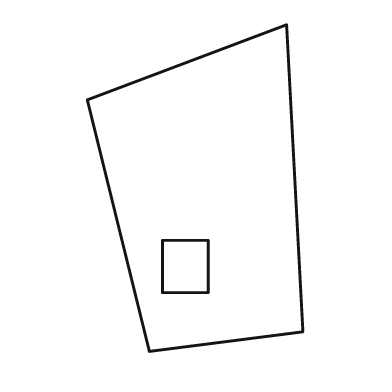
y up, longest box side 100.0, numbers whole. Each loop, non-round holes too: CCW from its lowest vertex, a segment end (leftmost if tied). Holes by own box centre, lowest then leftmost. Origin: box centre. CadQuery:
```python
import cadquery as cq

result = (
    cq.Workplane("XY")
    .moveTo(-14.0, -50.0)
    .lineTo(33.0, -44.0)
    .lineTo(28.0, 50.0)
    .lineTo(-33.0, 27.0)
    .close()
    .moveTo(-10.0, -32.0)
    .lineTo(4.0, -32.0)
    .lineTo(4.0, -16.0)
    .lineTo(-10.0, -16.0)
    .close()
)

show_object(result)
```